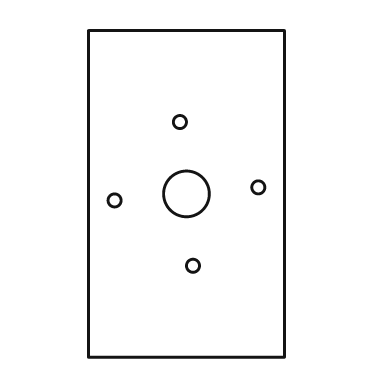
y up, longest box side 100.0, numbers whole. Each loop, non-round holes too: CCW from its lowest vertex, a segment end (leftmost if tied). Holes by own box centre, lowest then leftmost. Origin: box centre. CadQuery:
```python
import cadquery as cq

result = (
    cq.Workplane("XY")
    .moveTo(-30.0, -50.0)
    .lineTo(30.0, -50.0)
    .lineTo(30.0, 50.0)
    .lineTo(-30.0, 50.0)
    .close()
    .moveTo(2.0, -22.0)
    .circle(2.0)
    .moveTo(-22.0, -2.0)
    .circle(2.0)
    .moveTo(0.0, 0.0)
    .circle(7.0)
    .moveTo(22.0, 2.0)
    .circle(2.0)
    .moveTo(-2.0, 22.0)
    .circle(2.0)
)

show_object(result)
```